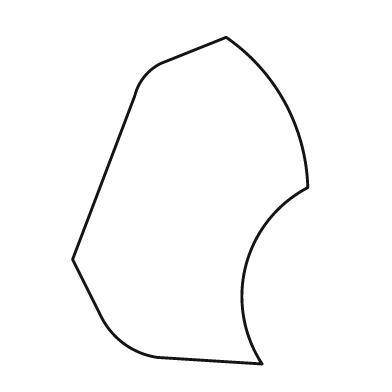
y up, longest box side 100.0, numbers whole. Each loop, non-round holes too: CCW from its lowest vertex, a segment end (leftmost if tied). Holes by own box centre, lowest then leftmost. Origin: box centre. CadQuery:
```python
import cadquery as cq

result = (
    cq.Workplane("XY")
    .moveTo(22.0, -50.0)
    .threePointArc((17.0, -20.0), (36.0, 4.0))
    .threePointArc((29.0, 30.0), (11.0, 50.0))
    .lineTo(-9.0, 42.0)
    .threePointArc((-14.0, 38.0), (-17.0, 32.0))
    .lineTo(-36.0, -18.0)
    .lineTo(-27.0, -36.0)
    .threePointArc((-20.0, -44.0), (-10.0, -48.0))
    .close()
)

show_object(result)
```